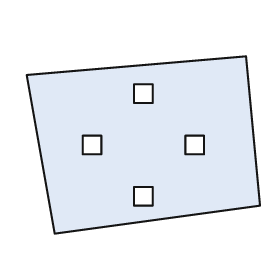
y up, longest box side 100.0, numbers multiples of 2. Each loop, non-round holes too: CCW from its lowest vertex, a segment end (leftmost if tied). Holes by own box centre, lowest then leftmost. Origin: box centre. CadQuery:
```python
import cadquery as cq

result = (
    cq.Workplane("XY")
    .moveTo(-38.0, -38.0)
    .lineTo(50.0, -26.0)
    .lineTo(44.0, 38.0)
    .lineTo(-50.0, 30.0)
    .close()
    .moveTo(-4.0, -26.0)
    .lineTo(4.0, -26.0)
    .lineTo(4.0, -18.0)
    .lineTo(-4.0, -18.0)
    .close()
    .moveTo(-26.0, -4.0)
    .lineTo(-18.0, -4.0)
    .lineTo(-18.0, 4.0)
    .lineTo(-26.0, 4.0)
    .close()
    .moveTo(18.0, -4.0)
    .lineTo(26.0, -4.0)
    .lineTo(26.0, 4.0)
    .lineTo(18.0, 4.0)
    .close()
    .moveTo(-4.0, 18.0)
    .lineTo(4.0, 18.0)
    .lineTo(4.0, 26.0)
    .lineTo(-4.0, 26.0)
    .close()
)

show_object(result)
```